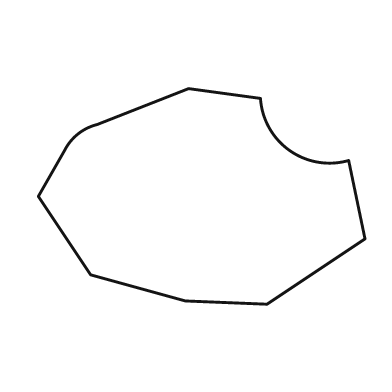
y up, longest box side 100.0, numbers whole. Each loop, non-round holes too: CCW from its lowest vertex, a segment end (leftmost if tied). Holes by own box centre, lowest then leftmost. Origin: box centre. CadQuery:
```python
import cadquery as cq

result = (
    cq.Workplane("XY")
    .moveTo(20.0, -33.0)
    .lineTo(50.0, -13.0)
    .lineTo(45.0, 11.0)
    .threePointArc((27.0, 14.0), (18.0, 30.0))
    .lineTo(-4.0, 33.0)
    .lineTo(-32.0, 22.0)
    .threePointArc((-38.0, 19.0), (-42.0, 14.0))
    .lineTo(-50.0, 0.0)
    .lineTo(-34.0, -24.0)
    .lineTo(-5.0, -32.0)
    .close()
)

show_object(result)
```